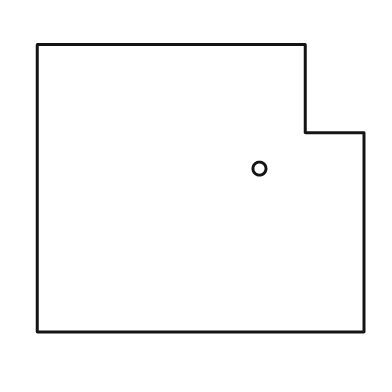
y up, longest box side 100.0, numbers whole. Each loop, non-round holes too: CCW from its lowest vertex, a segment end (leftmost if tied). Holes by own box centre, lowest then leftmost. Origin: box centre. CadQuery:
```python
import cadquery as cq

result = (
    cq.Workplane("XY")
    .moveTo(-50.0, -44.0)
    .lineTo(50.0, -44.0)
    .lineTo(50.0, 17.0)
    .lineTo(32.0, 17.0)
    .lineTo(32.0, 44.0)
    .lineTo(-50.0, 44.0)
    .close()
    .moveTo(18.0, 6.0)
    .circle(2.0)
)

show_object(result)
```